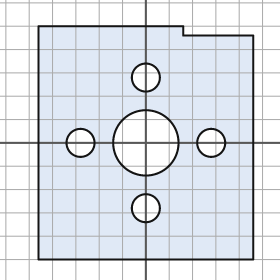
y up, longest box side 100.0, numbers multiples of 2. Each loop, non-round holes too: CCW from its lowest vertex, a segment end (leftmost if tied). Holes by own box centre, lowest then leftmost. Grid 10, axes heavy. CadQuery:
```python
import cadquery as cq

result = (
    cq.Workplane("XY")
    .moveTo(-46.0, -50.0)
    .lineTo(46.0, -50.0)
    .lineTo(46.0, 46.0)
    .lineTo(16.0, 46.0)
    .lineTo(16.0, 50.0)
    .lineTo(-46.0, 50.0)
    .close()
    .moveTo(0.0, -28.0)
    .circle(6.0)
    .moveTo(-28.0, 0.0)
    .circle(6.0)
    .moveTo(0.0, 0.0)
    .circle(14.0)
    .moveTo(28.0, 0.0)
    .circle(6.0)
    .moveTo(0.0, 28.0)
    .circle(6.0)
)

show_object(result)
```